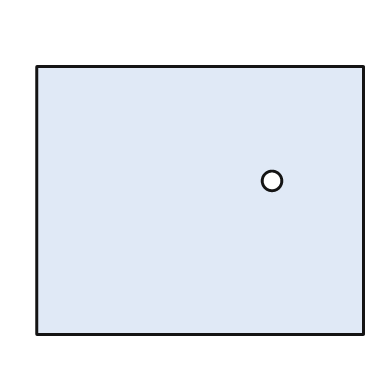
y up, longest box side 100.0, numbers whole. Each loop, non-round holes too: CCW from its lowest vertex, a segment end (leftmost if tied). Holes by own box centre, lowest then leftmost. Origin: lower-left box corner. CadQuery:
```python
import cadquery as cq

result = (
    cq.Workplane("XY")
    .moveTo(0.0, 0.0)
    .lineTo(100.0, 0.0)
    .lineTo(100.0, 82.0)
    .lineTo(0.0, 82.0)
    .close()
    .moveTo(72.0, 47.0)
    .circle(3.0)
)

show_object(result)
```